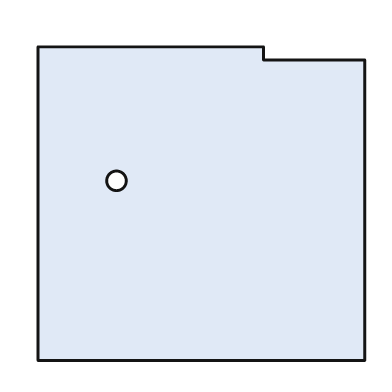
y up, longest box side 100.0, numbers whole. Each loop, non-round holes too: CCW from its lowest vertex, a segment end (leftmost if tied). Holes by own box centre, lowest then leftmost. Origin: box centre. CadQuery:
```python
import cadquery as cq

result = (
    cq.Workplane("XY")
    .moveTo(-50.0, -48.0)
    .lineTo(50.0, -48.0)
    .lineTo(50.0, 44.0)
    .lineTo(19.0, 44.0)
    .lineTo(19.0, 48.0)
    .lineTo(-50.0, 48.0)
    .close()
    .moveTo(-26.0, 7.0)
    .circle(3.0)
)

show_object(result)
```